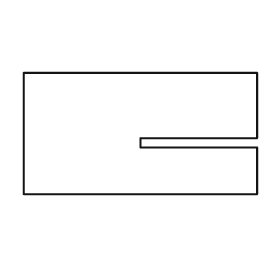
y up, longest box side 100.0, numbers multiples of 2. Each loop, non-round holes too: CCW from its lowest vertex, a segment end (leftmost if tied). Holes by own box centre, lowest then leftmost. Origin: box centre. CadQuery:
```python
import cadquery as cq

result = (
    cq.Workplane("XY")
    .moveTo(-50.0, -26.0)
    .lineTo(50.0, -26.0)
    .lineTo(50.0, -6.0)
    .lineTo(0.0, -6.0)
    .lineTo(0.0, -2.0)
    .lineTo(50.0, -2.0)
    .lineTo(50.0, 26.0)
    .lineTo(-50.0, 26.0)
    .close()
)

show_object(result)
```